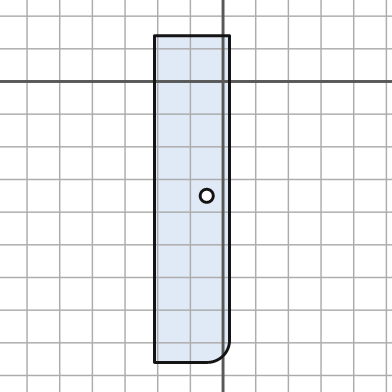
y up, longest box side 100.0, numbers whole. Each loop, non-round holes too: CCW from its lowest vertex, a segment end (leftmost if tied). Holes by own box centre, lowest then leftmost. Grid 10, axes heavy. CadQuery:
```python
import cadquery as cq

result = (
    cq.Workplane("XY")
    .moveTo(-21.0, -86.0)
    .lineTo(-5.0, -86.0)
    .threePointArc((0.0, -84.0), (2.0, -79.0))
    .lineTo(2.0, 14.0)
    .lineTo(-21.0, 14.0)
    .close()
    .moveTo(-5.0, -35.0)
    .circle(2.0)
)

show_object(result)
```